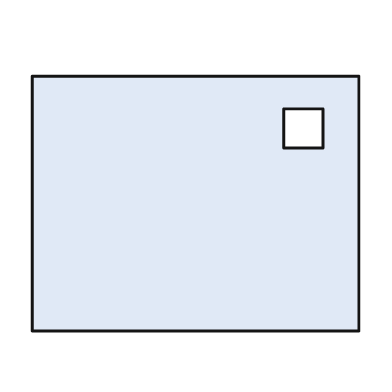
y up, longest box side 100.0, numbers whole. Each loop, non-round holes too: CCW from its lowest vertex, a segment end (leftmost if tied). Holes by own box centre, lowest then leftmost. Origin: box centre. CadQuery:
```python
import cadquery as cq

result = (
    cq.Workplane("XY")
    .moveTo(-50.0, -39.0)
    .lineTo(50.0, -39.0)
    .lineTo(50.0, 39.0)
    .lineTo(-50.0, 39.0)
    .close()
    .moveTo(27.0, 17.0)
    .lineTo(39.0, 17.0)
    .lineTo(39.0, 29.0)
    .lineTo(27.0, 29.0)
    .close()
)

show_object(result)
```